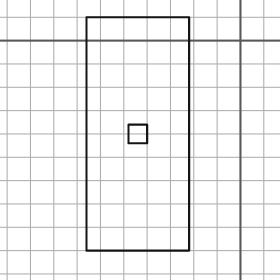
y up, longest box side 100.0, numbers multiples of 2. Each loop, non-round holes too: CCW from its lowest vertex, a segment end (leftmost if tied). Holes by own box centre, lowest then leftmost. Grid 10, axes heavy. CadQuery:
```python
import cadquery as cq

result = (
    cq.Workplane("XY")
    .moveTo(-66.0, -90.0)
    .lineTo(-22.0, -90.0)
    .lineTo(-22.0, 10.0)
    .lineTo(-66.0, 10.0)
    .close()
    .moveTo(-48.0, -44.0)
    .lineTo(-40.0, -44.0)
    .lineTo(-40.0, -36.0)
    .lineTo(-48.0, -36.0)
    .close()
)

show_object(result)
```